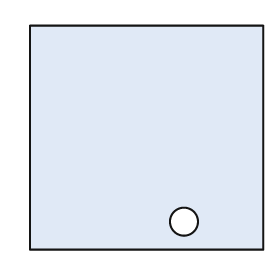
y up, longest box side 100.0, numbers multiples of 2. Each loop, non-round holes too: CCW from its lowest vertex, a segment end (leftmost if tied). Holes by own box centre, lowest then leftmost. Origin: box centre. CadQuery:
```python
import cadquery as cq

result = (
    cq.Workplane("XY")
    .moveTo(-50.0, -48.0)
    .lineTo(50.0, -48.0)
    .lineTo(50.0, 48.0)
    .lineTo(-50.0, 48.0)
    .close()
    .moveTo(16.0, -36.0)
    .circle(6.0)
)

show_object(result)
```